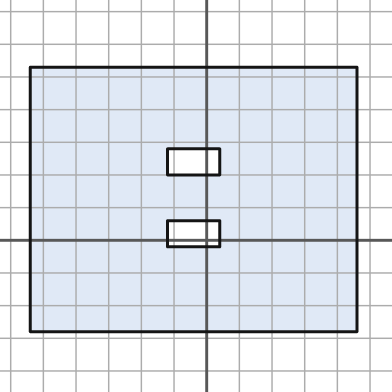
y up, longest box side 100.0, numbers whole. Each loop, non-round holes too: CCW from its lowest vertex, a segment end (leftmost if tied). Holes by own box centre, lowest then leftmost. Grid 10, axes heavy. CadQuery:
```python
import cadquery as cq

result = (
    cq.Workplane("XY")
    .moveTo(-54.0, -28.0)
    .lineTo(46.0, -28.0)
    .lineTo(46.0, 53.0)
    .lineTo(-54.0, 53.0)
    .close()
    .moveTo(-12.0, -2.0)
    .lineTo(4.0, -2.0)
    .lineTo(4.0, 6.0)
    .lineTo(-12.0, 6.0)
    .close()
    .moveTo(-12.0, 20.0)
    .lineTo(4.0, 20.0)
    .lineTo(4.0, 28.0)
    .lineTo(-12.0, 28.0)
    .close()
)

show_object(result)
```